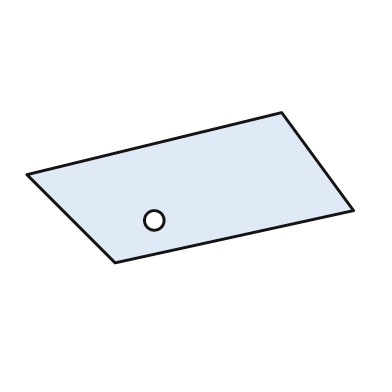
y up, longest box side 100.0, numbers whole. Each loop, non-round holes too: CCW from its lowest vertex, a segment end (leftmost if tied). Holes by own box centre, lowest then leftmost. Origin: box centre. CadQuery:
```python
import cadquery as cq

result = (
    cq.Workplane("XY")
    .moveTo(-23.0, -23.0)
    .lineTo(50.0, -7.0)
    .lineTo(28.0, 23.0)
    .lineTo(-50.0, 4.0)
    .close()
    .moveTo(-11.0, -10.0)
    .circle(3.0)
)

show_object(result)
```